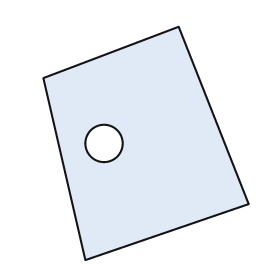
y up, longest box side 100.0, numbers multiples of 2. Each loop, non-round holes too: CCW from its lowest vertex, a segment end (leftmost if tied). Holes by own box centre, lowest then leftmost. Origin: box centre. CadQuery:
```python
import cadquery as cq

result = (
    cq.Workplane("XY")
    .moveTo(-26.0, -50.0)
    .lineTo(44.0, -26.0)
    .lineTo(14.0, 50.0)
    .lineTo(-44.0, 28.0)
    .close()
    .moveTo(-18.0, 0.0)
    .circle(8.0)
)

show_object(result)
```